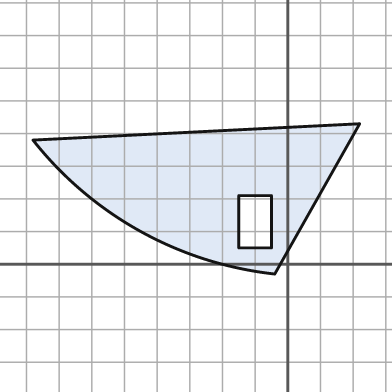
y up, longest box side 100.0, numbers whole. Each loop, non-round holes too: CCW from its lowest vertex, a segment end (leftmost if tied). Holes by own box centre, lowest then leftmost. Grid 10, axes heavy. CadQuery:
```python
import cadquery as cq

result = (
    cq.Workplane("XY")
    .moveTo(-4.0, -3.0)
    .lineTo(22.0, 43.0)
    .lineTo(-78.0, 38.0)
    .threePointArc((-45.0, 10.0), (-4.0, -3.0))
    .close()
    .moveTo(-15.0, 5.0)
    .lineTo(-5.0, 5.0)
    .lineTo(-5.0, 21.0)
    .lineTo(-15.0, 21.0)
    .close()
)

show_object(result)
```